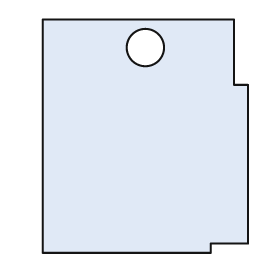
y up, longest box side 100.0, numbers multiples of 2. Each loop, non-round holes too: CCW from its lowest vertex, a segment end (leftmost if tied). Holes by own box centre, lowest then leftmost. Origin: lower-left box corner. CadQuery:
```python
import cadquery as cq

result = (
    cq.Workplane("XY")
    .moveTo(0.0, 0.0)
    .lineTo(72.0, 0.0)
    .lineTo(72.0, 4.0)
    .lineTo(88.0, 4.0)
    .lineTo(88.0, 72.0)
    .lineTo(82.0, 72.0)
    .lineTo(82.0, 100.0)
    .lineTo(0.0, 100.0)
    .close()
    .moveTo(44.0, 88.0)
    .circle(8.0)
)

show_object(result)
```